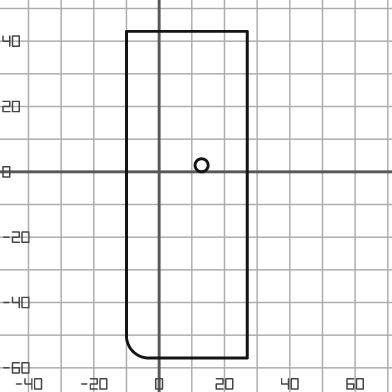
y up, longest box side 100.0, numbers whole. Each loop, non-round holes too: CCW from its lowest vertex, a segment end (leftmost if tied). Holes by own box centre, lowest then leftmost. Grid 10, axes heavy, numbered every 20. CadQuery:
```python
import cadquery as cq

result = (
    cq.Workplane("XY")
    .moveTo(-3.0, -57.0)
    .lineTo(27.0, -57.0)
    .lineTo(27.0, 43.0)
    .lineTo(-10.0, 43.0)
    .lineTo(-10.0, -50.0)
    .threePointArc((-8.0, -55.0), (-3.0, -57.0))
    .close()
    .moveTo(13.0, 2.0)
    .circle(2.0)
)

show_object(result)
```